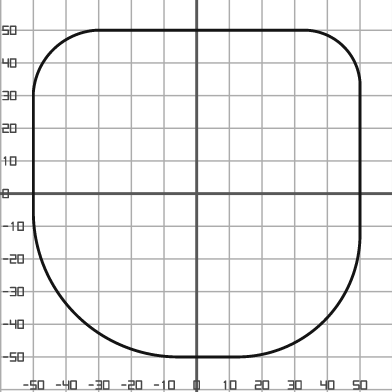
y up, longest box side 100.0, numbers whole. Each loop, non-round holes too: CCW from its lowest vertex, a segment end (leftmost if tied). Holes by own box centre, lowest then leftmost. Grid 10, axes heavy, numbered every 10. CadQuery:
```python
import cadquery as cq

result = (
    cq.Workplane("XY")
    .moveTo(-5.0, -50.0)
    .lineTo(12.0, -50.0)
    .threePointArc((39.0, -39.0), (50.0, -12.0))
    .lineTo(50.0, 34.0)
    .threePointArc((45.0, 45.0), (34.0, 50.0))
    .lineTo(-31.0, 50.0)
    .threePointArc((-44.0, 44.0), (-50.0, 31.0))
    .lineTo(-50.0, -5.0)
    .threePointArc((-37.0, -37.0), (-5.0, -50.0))
    .close()
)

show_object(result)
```